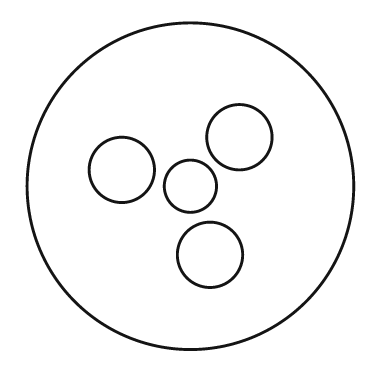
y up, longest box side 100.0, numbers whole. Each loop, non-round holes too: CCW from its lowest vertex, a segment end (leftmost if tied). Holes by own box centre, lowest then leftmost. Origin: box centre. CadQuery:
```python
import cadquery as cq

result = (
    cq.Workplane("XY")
    .moveTo(0.0, 0.0)
    .circle(50.0)
    .moveTo(6.0, -21.0)
    .circle(10.0)
    .moveTo(0.0, 0.0)
    .circle(8.0)
    .moveTo(-21.0, 5.0)
    .circle(10.0)
    .moveTo(15.0, 15.0)
    .circle(10.0)
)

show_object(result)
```